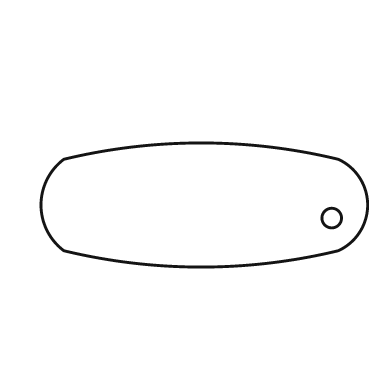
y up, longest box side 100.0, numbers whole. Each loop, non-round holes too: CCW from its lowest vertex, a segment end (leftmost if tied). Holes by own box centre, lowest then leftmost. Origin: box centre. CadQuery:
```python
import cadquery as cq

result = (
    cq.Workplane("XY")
    .moveTo(-43.0, -14.0)
    .threePointArc((-1.0, -19.0), (41.0, -14.0))
    .threePointArc((50.0, 0.0), (41.0, 14.0))
    .threePointArc((-1.0, 19.0), (-43.0, 14.0))
    .threePointArc((-50.0, 0.0), (-43.0, -14.0))
    .close()
    .moveTo(39.0, -4.0)
    .circle(3.0)
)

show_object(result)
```